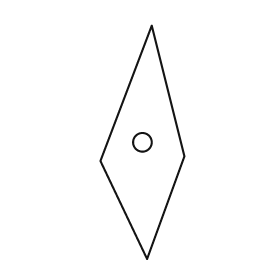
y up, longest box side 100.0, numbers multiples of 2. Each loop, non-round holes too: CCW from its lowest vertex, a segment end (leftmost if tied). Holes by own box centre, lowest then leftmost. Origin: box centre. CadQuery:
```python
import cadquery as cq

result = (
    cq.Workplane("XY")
    .moveTo(2.0, -50.0)
    .lineTo(18.0, -6.0)
    .lineTo(4.0, 50.0)
    .lineTo(-18.0, -8.0)
    .close()
    .moveTo(0.0, 0.0)
    .circle(4.0)
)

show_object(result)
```